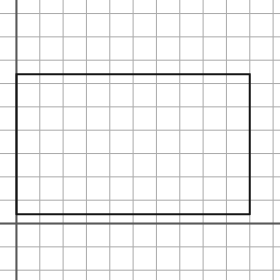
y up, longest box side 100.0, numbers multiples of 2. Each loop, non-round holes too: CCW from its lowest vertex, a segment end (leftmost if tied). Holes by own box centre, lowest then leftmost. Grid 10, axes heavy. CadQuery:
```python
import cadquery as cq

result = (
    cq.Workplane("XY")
    .moveTo(0.0, 4.0)
    .lineTo(100.0, 4.0)
    .lineTo(100.0, 64.0)
    .lineTo(0.0, 64.0)
    .close()
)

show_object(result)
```